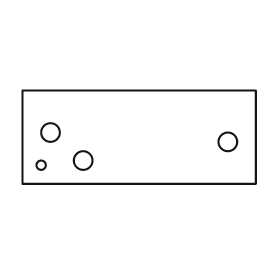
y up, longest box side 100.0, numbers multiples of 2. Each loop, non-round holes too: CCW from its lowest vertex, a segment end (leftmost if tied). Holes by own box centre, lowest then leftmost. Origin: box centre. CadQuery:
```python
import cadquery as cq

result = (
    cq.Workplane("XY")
    .moveTo(-50.0, -20.0)
    .lineTo(50.0, -20.0)
    .lineTo(50.0, 20.0)
    .lineTo(-50.0, 20.0)
    .close()
    .moveTo(-42.0, -12.0)
    .circle(2.0)
    .moveTo(-24.0, -10.0)
    .circle(4.0)
    .moveTo(38.0, -2.0)
    .circle(4.0)
    .moveTo(-38.0, 2.0)
    .circle(4.0)
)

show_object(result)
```